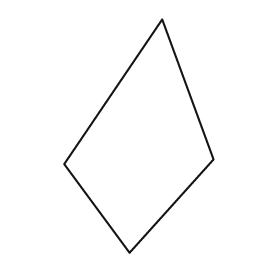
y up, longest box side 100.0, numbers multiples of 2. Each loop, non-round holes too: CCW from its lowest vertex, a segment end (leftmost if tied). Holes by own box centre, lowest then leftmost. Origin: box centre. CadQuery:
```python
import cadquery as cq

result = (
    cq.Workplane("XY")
    .moveTo(-4.0, -50.0)
    .lineTo(32.0, -10.0)
    .lineTo(10.0, 50.0)
    .lineTo(-32.0, -12.0)
    .close()
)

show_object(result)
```